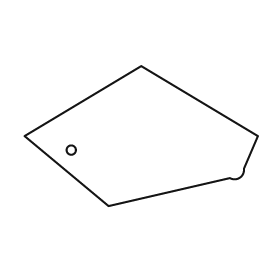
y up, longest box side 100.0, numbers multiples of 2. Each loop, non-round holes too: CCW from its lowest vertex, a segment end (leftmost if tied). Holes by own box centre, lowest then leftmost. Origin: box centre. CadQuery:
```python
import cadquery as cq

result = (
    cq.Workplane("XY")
    .moveTo(-14.0, -30.0)
    .lineTo(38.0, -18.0)
    .threePointArc((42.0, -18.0), (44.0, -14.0))
    .lineTo(50.0, 0.0)
    .lineTo(0.0, 30.0)
    .lineTo(-50.0, 0.0)
    .close()
    .moveTo(-30.0, -6.0)
    .circle(2.0)
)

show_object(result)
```